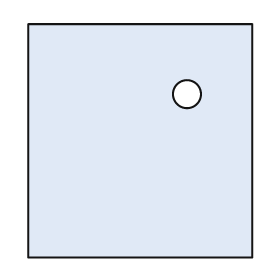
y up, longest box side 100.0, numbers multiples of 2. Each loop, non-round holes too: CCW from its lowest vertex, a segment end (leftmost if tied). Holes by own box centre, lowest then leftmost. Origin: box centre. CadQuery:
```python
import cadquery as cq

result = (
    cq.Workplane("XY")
    .moveTo(-48.0, -50.0)
    .lineTo(48.0, -50.0)
    .lineTo(48.0, 50.0)
    .lineTo(-48.0, 50.0)
    .close()
    .moveTo(20.0, 20.0)
    .circle(6.0)
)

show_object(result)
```